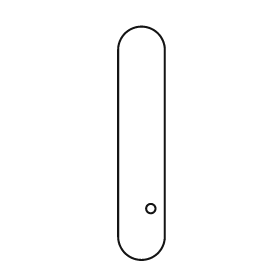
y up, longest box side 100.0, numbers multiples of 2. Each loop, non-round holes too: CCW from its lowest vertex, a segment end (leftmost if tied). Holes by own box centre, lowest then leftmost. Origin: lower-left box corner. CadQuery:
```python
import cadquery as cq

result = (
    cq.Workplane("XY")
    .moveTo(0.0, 10.0)
    .threePointArc((10.0, 0.0), (20.0, 10.0))
    .lineTo(20.0, 90.0)
    .threePointArc((10.0, 100.0), (0.0, 90.0))
    .close()
    .moveTo(14.0, 22.0)
    .circle(2.0)
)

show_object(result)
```